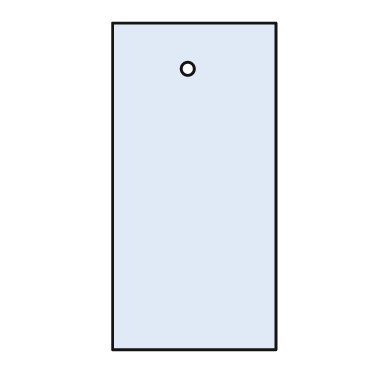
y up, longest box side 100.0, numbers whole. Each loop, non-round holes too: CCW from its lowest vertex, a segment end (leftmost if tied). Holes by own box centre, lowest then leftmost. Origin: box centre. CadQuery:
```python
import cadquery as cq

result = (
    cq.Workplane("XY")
    .moveTo(-25.0, -50.0)
    .lineTo(25.0, -50.0)
    .lineTo(25.0, 50.0)
    .lineTo(-25.0, 50.0)
    .close()
    .moveTo(-2.0, 36.0)
    .circle(2.0)
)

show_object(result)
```